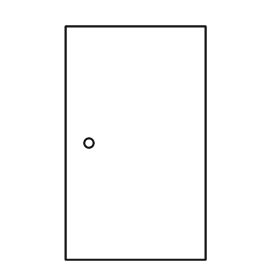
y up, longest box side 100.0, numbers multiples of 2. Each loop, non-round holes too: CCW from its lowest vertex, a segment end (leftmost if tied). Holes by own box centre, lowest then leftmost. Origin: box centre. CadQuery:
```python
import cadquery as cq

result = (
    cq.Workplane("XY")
    .moveTo(-30.0, -50.0)
    .lineTo(30.0, -50.0)
    .lineTo(30.0, 50.0)
    .lineTo(-30.0, 50.0)
    .close()
    .moveTo(-20.0, 0.0)
    .circle(2.0)
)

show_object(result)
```